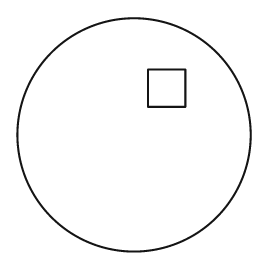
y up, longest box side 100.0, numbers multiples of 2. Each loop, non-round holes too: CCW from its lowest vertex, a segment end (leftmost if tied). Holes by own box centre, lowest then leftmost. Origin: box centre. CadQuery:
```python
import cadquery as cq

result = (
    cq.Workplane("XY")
    .moveTo(0.0, 0.0)
    .circle(50.0)
    .moveTo(6.0, 12.0)
    .lineTo(22.0, 12.0)
    .lineTo(22.0, 28.0)
    .lineTo(6.0, 28.0)
    .close()
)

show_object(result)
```